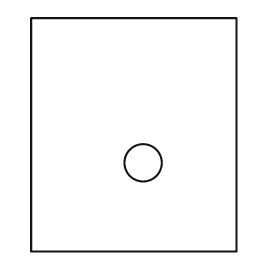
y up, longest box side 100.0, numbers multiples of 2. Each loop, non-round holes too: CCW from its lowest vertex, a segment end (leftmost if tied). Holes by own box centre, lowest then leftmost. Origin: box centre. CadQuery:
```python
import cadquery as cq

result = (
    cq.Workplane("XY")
    .moveTo(-44.0, -50.0)
    .lineTo(44.0, -50.0)
    .lineTo(44.0, 50.0)
    .lineTo(-44.0, 50.0)
    .close()
    .moveTo(4.0, -12.0)
    .circle(8.0)
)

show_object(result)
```